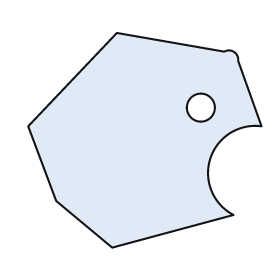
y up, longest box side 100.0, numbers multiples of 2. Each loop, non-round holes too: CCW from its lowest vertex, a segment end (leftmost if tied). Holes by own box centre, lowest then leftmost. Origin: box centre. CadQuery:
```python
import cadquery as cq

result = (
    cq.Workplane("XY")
    .moveTo(-14.0, -46.0)
    .lineTo(38.0, -32.0)
    .threePointArc((28.0, -8.0), (50.0, 6.0))
    .lineTo(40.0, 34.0)
    .threePointArc((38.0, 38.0), (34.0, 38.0))
    .lineTo(-12.0, 46.0)
    .lineTo(-50.0, 6.0)
    .lineTo(-38.0, -26.0)
    .close()
    .moveTo(24.0, 14.0)
    .circle(6.0)
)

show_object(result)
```